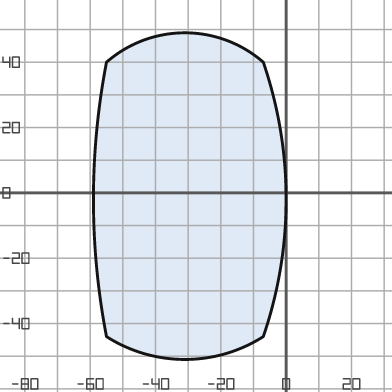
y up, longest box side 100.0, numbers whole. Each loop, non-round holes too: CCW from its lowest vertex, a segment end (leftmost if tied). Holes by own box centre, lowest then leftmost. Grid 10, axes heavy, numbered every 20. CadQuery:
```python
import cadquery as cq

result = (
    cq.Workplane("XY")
    .moveTo(-55.0, -44.0)
    .threePointArc((-31.0, -51.0), (-7.0, -44.0))
    .threePointArc((0.0, -2.0), (-7.0, 40.0))
    .threePointArc((-31.0, 49.0), (-55.0, 40.0))
    .threePointArc((-59.0, -2.0), (-55.0, -44.0))
    .close()
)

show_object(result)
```